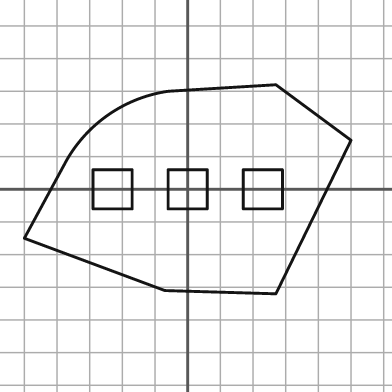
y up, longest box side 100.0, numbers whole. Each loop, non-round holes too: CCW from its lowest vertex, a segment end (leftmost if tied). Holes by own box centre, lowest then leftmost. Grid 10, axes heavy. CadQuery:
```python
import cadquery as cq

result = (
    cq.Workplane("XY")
    .moveTo(27.0, -32.0)
    .lineTo(50.0, 15.0)
    .lineTo(27.0, 32.0)
    .lineTo(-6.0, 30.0)
    .threePointArc((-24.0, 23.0), (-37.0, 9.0))
    .lineTo(-50.0, -15.0)
    .lineTo(-7.0, -31.0)
    .close()
    .moveTo(-29.0, -6.0)
    .lineTo(-17.0, -6.0)
    .lineTo(-17.0, 6.0)
    .lineTo(-29.0, 6.0)
    .close()
    .moveTo(-6.0, -6.0)
    .lineTo(6.0, -6.0)
    .lineTo(6.0, 6.0)
    .lineTo(-6.0, 6.0)
    .close()
    .moveTo(17.0, -6.0)
    .lineTo(29.0, -6.0)
    .lineTo(29.0, 6.0)
    .lineTo(17.0, 6.0)
    .close()
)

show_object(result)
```